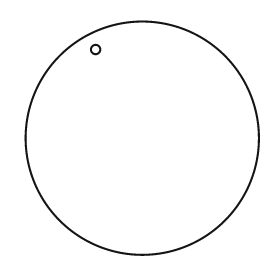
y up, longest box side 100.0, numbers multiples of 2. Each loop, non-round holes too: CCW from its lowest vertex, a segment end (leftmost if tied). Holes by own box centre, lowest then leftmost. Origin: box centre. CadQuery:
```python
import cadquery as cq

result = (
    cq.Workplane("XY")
    .moveTo(0.0, 0.0)
    .circle(50.0)
    .moveTo(-20.0, 38.0)
    .circle(2.0)
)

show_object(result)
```